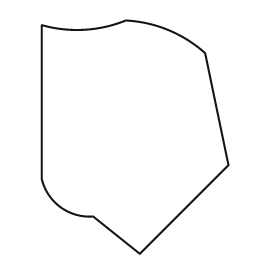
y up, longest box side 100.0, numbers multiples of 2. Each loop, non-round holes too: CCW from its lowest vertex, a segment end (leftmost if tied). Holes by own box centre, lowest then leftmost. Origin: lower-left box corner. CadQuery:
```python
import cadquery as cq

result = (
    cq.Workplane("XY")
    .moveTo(42.0, 0.0)
    .lineTo(80.0, 38.0)
    .lineTo(70.0, 86.0)
    .threePointArc((54.0, 96.0), (36.0, 100.0))
    .threePointArc((18.0, 96.0), (0.0, 98.0))
    .lineTo(0.0, 32.0)
    .threePointArc((8.0, 20.0), (22.0, 16.0))
    .close()
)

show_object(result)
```